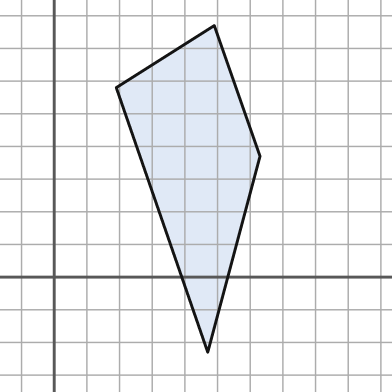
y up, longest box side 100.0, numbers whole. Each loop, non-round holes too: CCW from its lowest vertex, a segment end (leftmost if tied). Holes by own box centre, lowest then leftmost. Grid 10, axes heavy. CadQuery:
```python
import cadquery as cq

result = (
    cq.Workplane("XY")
    .moveTo(47.0, -23.0)
    .lineTo(63.0, 37.0)
    .lineTo(49.0, 77.0)
    .lineTo(19.0, 58.0)
    .close()
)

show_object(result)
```